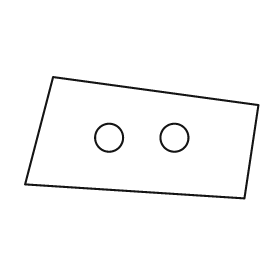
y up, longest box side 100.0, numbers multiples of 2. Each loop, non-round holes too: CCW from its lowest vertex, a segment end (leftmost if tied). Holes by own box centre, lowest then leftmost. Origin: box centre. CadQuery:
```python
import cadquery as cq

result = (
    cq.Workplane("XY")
    .moveTo(44.0, -26.0)
    .lineTo(50.0, 14.0)
    .lineTo(-38.0, 26.0)
    .lineTo(-50.0, -20.0)
    .close()
    .moveTo(-14.0, 0.0)
    .circle(6.0)
    .moveTo(14.0, 0.0)
    .circle(6.0)
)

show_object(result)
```